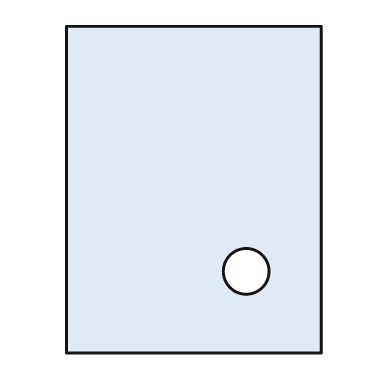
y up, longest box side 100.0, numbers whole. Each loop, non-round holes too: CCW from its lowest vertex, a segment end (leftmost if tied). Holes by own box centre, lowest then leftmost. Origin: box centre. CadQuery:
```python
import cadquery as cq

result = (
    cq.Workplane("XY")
    .moveTo(-39.0, -50.0)
    .lineTo(39.0, -50.0)
    .lineTo(39.0, 50.0)
    .lineTo(-39.0, 50.0)
    .close()
    .moveTo(16.0, -25.0)
    .circle(7.0)
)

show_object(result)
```